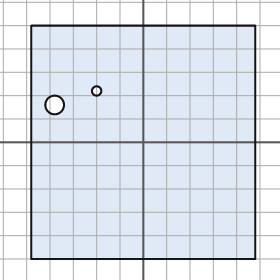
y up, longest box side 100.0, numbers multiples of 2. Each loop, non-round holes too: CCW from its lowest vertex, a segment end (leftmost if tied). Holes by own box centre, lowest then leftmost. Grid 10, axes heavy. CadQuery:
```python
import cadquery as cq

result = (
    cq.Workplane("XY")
    .moveTo(-48.0, -50.0)
    .lineTo(48.0, -50.0)
    .lineTo(48.0, 50.0)
    .lineTo(-48.0, 50.0)
    .close()
    .moveTo(-38.0, 16.0)
    .circle(4.0)
    .moveTo(-20.0, 22.0)
    .circle(2.0)
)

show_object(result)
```